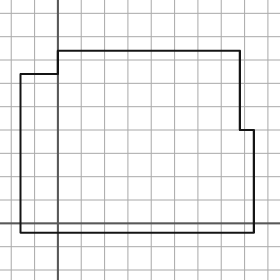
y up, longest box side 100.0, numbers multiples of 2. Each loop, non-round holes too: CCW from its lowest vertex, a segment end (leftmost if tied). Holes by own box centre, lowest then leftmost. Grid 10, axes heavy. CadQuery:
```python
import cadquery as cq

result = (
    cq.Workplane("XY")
    .moveTo(-16.0, -4.0)
    .lineTo(84.0, -4.0)
    .lineTo(84.0, 40.0)
    .lineTo(78.0, 40.0)
    .lineTo(78.0, 74.0)
    .lineTo(0.0, 74.0)
    .lineTo(0.0, 64.0)
    .lineTo(-16.0, 64.0)
    .close()
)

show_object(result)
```